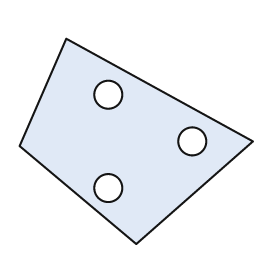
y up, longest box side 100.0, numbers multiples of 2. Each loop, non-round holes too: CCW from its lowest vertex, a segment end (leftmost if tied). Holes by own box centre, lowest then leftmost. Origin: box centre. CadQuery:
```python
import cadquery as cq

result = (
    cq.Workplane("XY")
    .moveTo(0.0, -44.0)
    .lineTo(50.0, 0.0)
    .lineTo(-30.0, 44.0)
    .lineTo(-50.0, -2.0)
    .close()
    .moveTo(-12.0, -20.0)
    .circle(6.0)
    .moveTo(24.0, 0.0)
    .circle(6.0)
    .moveTo(-12.0, 20.0)
    .circle(6.0)
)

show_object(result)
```